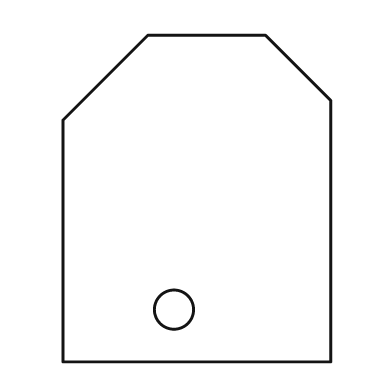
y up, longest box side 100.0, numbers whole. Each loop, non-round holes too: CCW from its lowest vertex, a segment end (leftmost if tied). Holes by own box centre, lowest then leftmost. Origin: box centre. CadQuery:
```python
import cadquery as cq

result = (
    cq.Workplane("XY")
    .moveTo(-41.0, -50.0)
    .lineTo(41.0, -50.0)
    .lineTo(41.0, 30.0)
    .lineTo(21.0, 50.0)
    .lineTo(-15.0, 50.0)
    .lineTo(-41.0, 24.0)
    .close()
    .moveTo(-7.0, -34.0)
    .circle(6.0)
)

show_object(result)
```